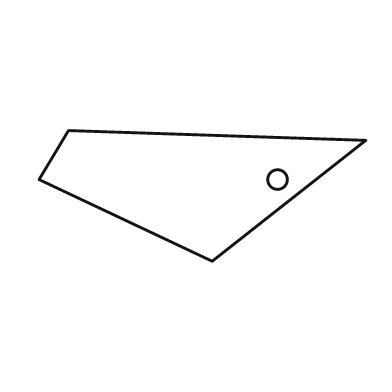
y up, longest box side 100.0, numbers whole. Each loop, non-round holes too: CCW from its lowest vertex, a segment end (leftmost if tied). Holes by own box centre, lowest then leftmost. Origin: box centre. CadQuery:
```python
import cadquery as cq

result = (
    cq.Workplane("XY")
    .moveTo(3.0, -20.0)
    .lineTo(50.0, 17.0)
    .lineTo(-41.0, 20.0)
    .lineTo(-50.0, 5.0)
    .close()
    .moveTo(23.0, 5.0)
    .circle(3.0)
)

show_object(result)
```